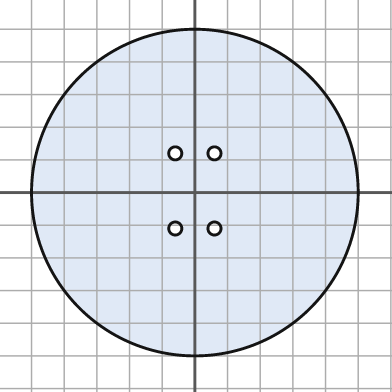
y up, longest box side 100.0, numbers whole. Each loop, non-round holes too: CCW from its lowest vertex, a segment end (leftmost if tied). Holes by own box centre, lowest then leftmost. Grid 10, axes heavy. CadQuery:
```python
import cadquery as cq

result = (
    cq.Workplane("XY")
    .moveTo(0.0, 0.0)
    .circle(50.0)
    .moveTo(-6.0, -11.0)
    .circle(2.0)
    .moveTo(6.0, -11.0)
    .circle(2.0)
    .moveTo(-6.0, 12.0)
    .circle(2.0)
    .moveTo(6.0, 12.0)
    .circle(2.0)
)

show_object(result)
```